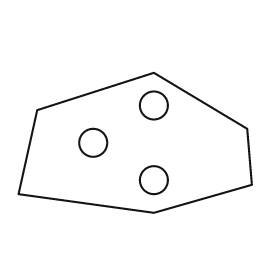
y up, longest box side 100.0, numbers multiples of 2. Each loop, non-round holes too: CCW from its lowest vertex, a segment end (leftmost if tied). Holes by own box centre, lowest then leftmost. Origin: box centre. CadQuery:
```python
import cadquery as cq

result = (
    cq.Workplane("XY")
    .moveTo(8.0, -30.0)
    .lineTo(50.0, -18.0)
    .lineTo(48.0, 6.0)
    .lineTo(8.0, 30.0)
    .lineTo(-42.0, 14.0)
    .lineTo(-50.0, -22.0)
    .close()
    .moveTo(8.0, -16.0)
    .circle(6.0)
    .moveTo(-18.0, 0.0)
    .circle(6.0)
    .moveTo(8.0, 16.0)
    .circle(6.0)
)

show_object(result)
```